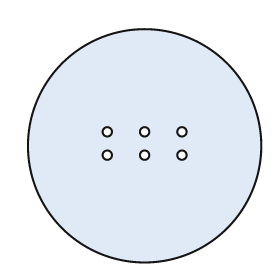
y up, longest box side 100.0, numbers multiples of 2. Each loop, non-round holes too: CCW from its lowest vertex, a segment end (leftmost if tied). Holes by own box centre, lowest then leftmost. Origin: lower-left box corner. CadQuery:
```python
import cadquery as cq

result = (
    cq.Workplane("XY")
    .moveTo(50.0, 50.0)
    .circle(50.0)
    .moveTo(34.0, 46.0)
    .circle(2.0)
    .moveTo(50.0, 46.0)
    .circle(2.0)
    .moveTo(66.0, 46.0)
    .circle(2.0)
    .moveTo(34.0, 56.0)
    .circle(2.0)
    .moveTo(50.0, 56.0)
    .circle(2.0)
    .moveTo(66.0, 56.0)
    .circle(2.0)
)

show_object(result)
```